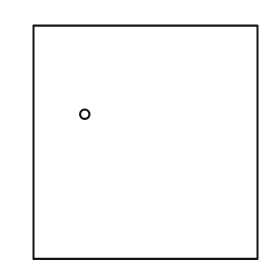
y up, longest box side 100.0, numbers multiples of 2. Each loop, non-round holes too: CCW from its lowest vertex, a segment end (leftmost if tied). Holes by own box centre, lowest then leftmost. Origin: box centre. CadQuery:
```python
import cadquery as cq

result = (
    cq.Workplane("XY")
    .moveTo(-48.0, -50.0)
    .lineTo(48.0, -50.0)
    .lineTo(48.0, 50.0)
    .lineTo(-48.0, 50.0)
    .close()
    .moveTo(-26.0, 12.0)
    .circle(2.0)
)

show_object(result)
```